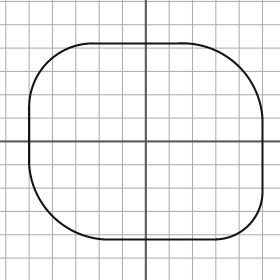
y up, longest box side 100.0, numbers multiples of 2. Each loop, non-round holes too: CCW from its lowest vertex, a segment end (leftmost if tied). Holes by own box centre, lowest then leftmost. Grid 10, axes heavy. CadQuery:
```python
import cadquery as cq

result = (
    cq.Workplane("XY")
    .moveTo(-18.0, -42.0)
    .lineTo(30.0, -42.0)
    .threePointArc((44.0, -36.0), (50.0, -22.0))
    .lineTo(50.0, 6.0)
    .threePointArc((40.0, 32.0), (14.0, 42.0))
    .lineTo(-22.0, 42.0)
    .threePointArc((-42.0, 34.0), (-50.0, 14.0))
    .lineTo(-50.0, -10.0)
    .threePointArc((-40.0, -32.0), (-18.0, -42.0))
    .close()
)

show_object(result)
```